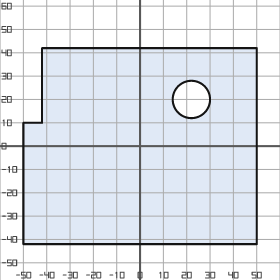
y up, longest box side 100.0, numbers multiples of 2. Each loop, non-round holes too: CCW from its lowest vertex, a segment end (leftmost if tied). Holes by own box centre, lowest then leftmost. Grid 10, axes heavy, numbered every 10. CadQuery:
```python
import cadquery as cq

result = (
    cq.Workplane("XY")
    .moveTo(-50.0, -42.0)
    .lineTo(50.0, -42.0)
    .lineTo(50.0, 42.0)
    .lineTo(-42.0, 42.0)
    .lineTo(-42.0, 10.0)
    .lineTo(-50.0, 10.0)
    .close()
    .moveTo(22.0, 20.0)
    .circle(8.0)
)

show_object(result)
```